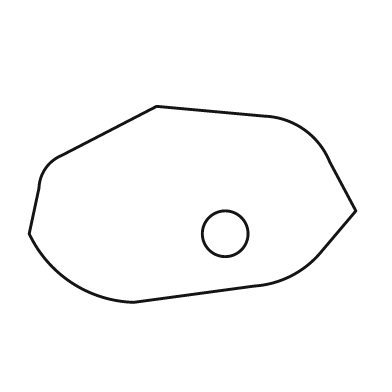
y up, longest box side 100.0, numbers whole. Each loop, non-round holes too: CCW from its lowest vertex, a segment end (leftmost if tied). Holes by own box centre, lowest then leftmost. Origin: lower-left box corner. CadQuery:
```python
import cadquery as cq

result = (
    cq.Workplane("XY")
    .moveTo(32.0, 0.0)
    .lineTo(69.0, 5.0)
    .threePointArc((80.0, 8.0), (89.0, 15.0))
    .lineTo(100.0, 28.0)
    .lineTo(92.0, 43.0)
    .threePointArc((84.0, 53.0), (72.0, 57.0))
    .lineTo(39.0, 60.0)
    .lineTo(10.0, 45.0)
    .threePointArc((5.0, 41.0), (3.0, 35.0))
    .lineTo(0.0, 21.0)
    .threePointArc((13.0, 6.0), (32.0, 0.0))
    .close()
    .moveTo(60.0, 21.0)
    .circle(7.0)
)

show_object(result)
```